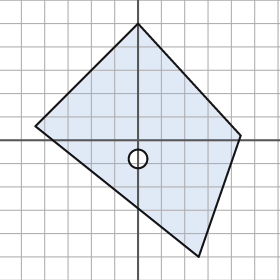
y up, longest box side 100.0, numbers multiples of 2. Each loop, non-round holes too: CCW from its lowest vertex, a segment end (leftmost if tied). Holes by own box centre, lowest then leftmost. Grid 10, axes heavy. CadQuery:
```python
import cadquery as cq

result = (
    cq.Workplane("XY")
    .moveTo(26.0, -50.0)
    .lineTo(44.0, 2.0)
    .lineTo(0.0, 50.0)
    .lineTo(-44.0, 6.0)
    .close()
    .moveTo(0.0, -8.0)
    .circle(4.0)
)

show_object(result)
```